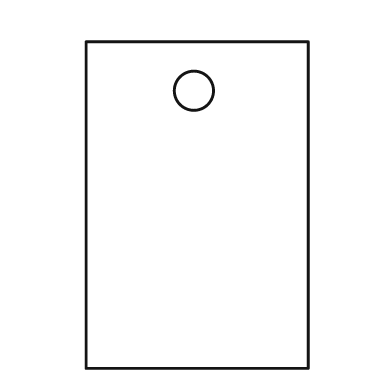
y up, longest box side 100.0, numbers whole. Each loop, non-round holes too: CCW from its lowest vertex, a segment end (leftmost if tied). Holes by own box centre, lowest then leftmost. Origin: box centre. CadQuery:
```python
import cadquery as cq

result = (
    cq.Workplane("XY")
    .moveTo(-34.0, -50.0)
    .lineTo(34.0, -50.0)
    .lineTo(34.0, 50.0)
    .lineTo(-34.0, 50.0)
    .close()
    .moveTo(-1.0, 35.0)
    .circle(6.0)
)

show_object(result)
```